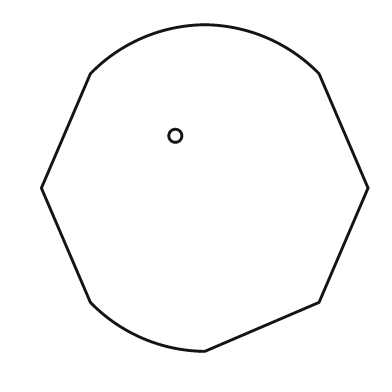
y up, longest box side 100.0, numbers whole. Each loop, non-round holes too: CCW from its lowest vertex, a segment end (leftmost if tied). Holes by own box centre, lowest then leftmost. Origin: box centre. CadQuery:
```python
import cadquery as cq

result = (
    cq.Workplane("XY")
    .moveTo(0.0, -50.0)
    .lineTo(35.0, -35.0)
    .lineTo(50.0, 0.0)
    .lineTo(35.0, 35.0)
    .threePointArc((19.0, 46.0), (0.0, 50.0))
    .threePointArc((-19.0, 46.0), (-35.0, 35.0))
    .lineTo(-50.0, 0.0)
    .lineTo(-35.0, -35.0)
    .threePointArc((-19.0, -46.0), (0.0, -50.0))
    .close()
    .moveTo(-9.0, 16.0)
    .circle(2.0)
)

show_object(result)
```